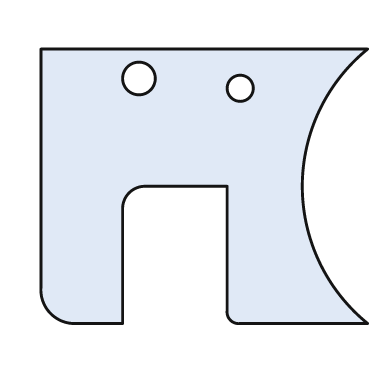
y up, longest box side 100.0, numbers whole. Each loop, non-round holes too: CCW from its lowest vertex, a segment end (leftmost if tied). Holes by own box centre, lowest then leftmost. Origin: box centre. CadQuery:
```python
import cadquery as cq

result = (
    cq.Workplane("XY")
    .moveTo(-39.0, -42.0)
    .lineTo(-25.0, -42.0)
    .lineTo(-25.0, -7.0)
    .threePointArc((-23.0, -2.0), (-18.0, 0.0))
    .lineTo(7.0, 0.0)
    .lineTo(7.0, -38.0)
    .threePointArc((8.0, -41.0), (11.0, -42.0))
    .lineTo(50.0, -42.0)
    .threePointArc((30.0, 0.0), (50.0, 42.0))
    .lineTo(-50.0, 42.0)
    .lineTo(-50.0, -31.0)
    .threePointArc((-47.0, -39.0), (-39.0, -42.0))
    .close()
    .moveTo(11.0, 30.0)
    .circle(4.0)
    .moveTo(-20.0, 33.0)
    .circle(5.0)
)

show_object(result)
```